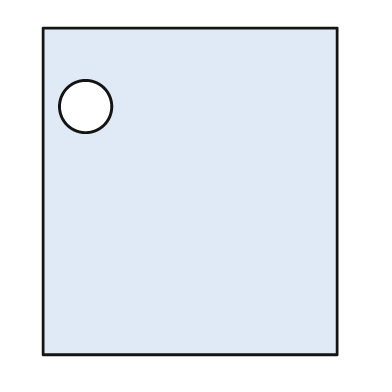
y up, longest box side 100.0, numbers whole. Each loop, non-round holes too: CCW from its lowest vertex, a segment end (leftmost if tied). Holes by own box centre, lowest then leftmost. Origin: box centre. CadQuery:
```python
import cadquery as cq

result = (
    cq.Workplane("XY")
    .moveTo(-45.0, -50.0)
    .lineTo(45.0, -50.0)
    .lineTo(45.0, 50.0)
    .lineTo(-45.0, 50.0)
    .close()
    .moveTo(-32.0, 26.0)
    .circle(8.0)
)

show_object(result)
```